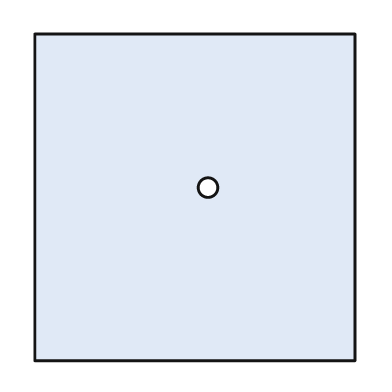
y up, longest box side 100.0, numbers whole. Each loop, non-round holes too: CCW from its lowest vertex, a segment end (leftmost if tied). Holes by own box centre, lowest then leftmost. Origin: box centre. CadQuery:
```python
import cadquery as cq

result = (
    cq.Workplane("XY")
    .moveTo(-49.0, -50.0)
    .lineTo(49.0, -50.0)
    .lineTo(49.0, 50.0)
    .lineTo(-49.0, 50.0)
    .close()
    .moveTo(4.0, 3.0)
    .circle(3.0)
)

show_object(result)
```